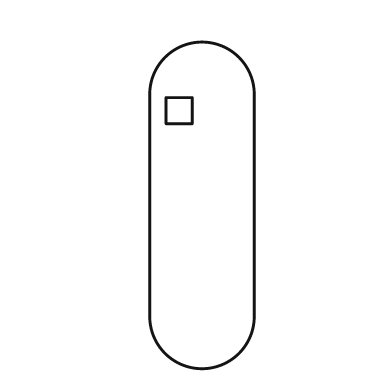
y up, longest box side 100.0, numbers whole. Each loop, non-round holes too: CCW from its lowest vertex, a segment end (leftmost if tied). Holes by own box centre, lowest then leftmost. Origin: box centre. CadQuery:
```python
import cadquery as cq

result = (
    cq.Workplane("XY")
    .moveTo(-16.0, -34.0)
    .threePointArc((0.0, -50.0), (16.0, -34.0))
    .lineTo(16.0, 34.0)
    .threePointArc((0.0, 50.0), (-16.0, 34.0))
    .close()
    .moveTo(-11.0, 25.0)
    .lineTo(-3.0, 25.0)
    .lineTo(-3.0, 33.0)
    .lineTo(-11.0, 33.0)
    .close()
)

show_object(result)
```